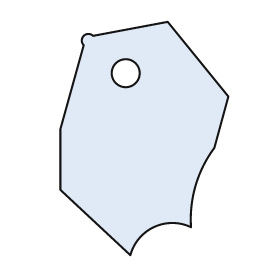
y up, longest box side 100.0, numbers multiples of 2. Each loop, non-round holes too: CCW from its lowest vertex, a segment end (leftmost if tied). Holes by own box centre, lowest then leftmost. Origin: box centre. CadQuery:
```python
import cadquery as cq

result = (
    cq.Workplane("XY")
    .moveTo(-6.0, -50.0)
    .threePointArc((4.0, -38.0), (20.0, -38.0))
    .threePointArc((22.0, -20.0), (30.0, -4.0))
    .lineTo(36.0, 18.0)
    .lineTo(10.0, 50.0)
    .lineTo(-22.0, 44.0)
    .threePointArc((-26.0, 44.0), (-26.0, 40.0))
    .lineTo(-36.0, 4.0)
    .lineTo(-36.0, -22.0)
    .close()
    .moveTo(-8.0, 28.0)
    .circle(6.0)
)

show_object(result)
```